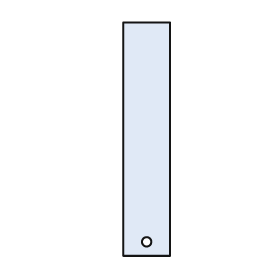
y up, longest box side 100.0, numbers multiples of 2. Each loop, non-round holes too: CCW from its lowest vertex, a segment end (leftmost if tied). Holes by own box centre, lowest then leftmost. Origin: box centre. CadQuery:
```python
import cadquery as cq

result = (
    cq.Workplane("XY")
    .moveTo(-10.0, -50.0)
    .lineTo(10.0, -50.0)
    .lineTo(10.0, 50.0)
    .lineTo(-10.0, 50.0)
    .close()
    .moveTo(0.0, -44.0)
    .circle(2.0)
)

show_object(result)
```